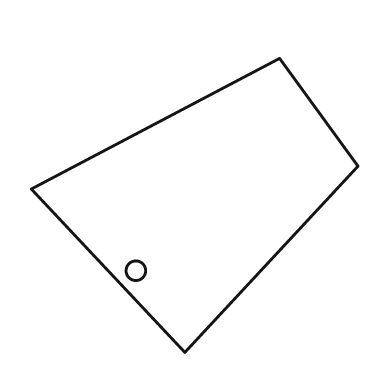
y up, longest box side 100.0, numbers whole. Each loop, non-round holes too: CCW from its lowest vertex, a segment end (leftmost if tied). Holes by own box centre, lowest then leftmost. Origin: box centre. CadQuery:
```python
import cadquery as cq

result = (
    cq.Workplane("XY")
    .moveTo(-3.0, -45.0)
    .lineTo(50.0, 12.0)
    .lineTo(26.0, 45.0)
    .lineTo(-50.0, 5.0)
    .close()
    .moveTo(-18.0, -20.0)
    .circle(3.0)
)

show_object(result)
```